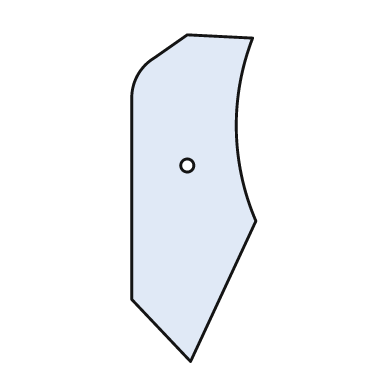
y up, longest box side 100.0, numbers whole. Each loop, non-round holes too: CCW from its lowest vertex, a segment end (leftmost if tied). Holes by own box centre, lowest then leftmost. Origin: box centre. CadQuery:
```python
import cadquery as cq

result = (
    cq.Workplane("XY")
    .moveTo(-1.0, -50.0)
    .lineTo(19.0, -7.0)
    .threePointArc((13.0, 21.0), (18.0, 49.0))
    .lineTo(-2.0, 50.0)
    .lineTo(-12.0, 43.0)
    .threePointArc((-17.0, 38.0), (-19.0, 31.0))
    .lineTo(-19.0, -31.0)
    .close()
    .moveTo(-2.0, 10.0)
    .circle(2.0)
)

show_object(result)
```